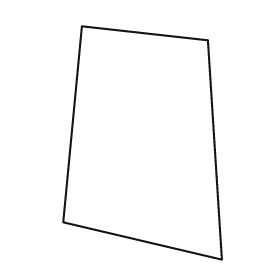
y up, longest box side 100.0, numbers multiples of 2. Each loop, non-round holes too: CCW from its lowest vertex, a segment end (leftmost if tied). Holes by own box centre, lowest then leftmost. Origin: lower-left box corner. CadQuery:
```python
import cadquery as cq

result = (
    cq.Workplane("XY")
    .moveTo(68.0, 0.0)
    .lineTo(62.0, 94.0)
    .lineTo(8.0, 100.0)
    .lineTo(0.0, 16.0)
    .close()
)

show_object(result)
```